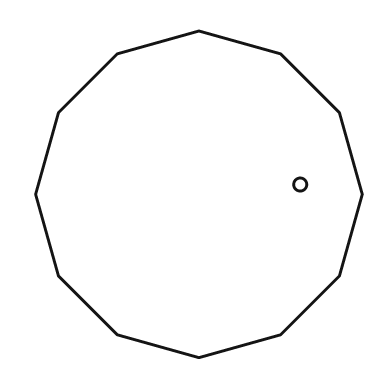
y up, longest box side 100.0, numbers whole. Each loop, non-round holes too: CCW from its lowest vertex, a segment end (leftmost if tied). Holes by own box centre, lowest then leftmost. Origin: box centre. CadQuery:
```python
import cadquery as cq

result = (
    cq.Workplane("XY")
    .moveTo(0.0, -50.0)
    .lineTo(25.0, -43.0)
    .lineTo(43.0, -25.0)
    .lineTo(50.0, 0.0)
    .lineTo(43.0, 25.0)
    .lineTo(25.0, 43.0)
    .lineTo(0.0, 50.0)
    .lineTo(-25.0, 43.0)
    .lineTo(-43.0, 25.0)
    .lineTo(-50.0, 0.0)
    .lineTo(-43.0, -25.0)
    .lineTo(-25.0, -43.0)
    .close()
    .moveTo(31.0, 3.0)
    .circle(2.0)
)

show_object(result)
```